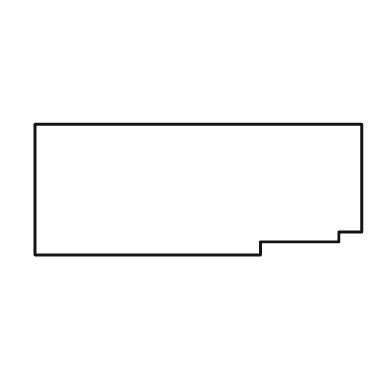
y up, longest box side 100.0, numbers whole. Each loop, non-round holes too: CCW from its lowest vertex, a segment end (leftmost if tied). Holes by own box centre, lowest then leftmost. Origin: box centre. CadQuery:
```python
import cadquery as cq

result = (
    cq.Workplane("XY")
    .moveTo(-50.0, -20.0)
    .lineTo(19.0, -20.0)
    .lineTo(19.0, -16.0)
    .lineTo(43.0, -16.0)
    .lineTo(43.0, -13.0)
    .lineTo(50.0, -13.0)
    .lineTo(50.0, 20.0)
    .lineTo(-50.0, 20.0)
    .close()
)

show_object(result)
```